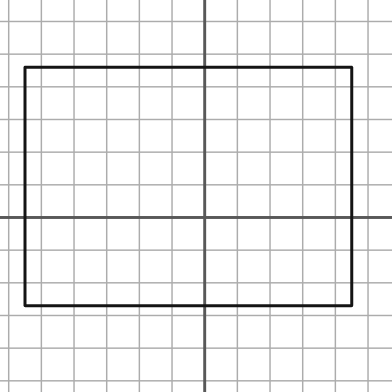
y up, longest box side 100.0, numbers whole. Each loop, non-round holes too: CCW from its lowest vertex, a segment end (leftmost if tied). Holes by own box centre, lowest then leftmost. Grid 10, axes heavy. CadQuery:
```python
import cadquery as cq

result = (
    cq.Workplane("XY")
    .moveTo(-55.0, -27.0)
    .lineTo(45.0, -27.0)
    .lineTo(45.0, 46.0)
    .lineTo(-55.0, 46.0)
    .close()
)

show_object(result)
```